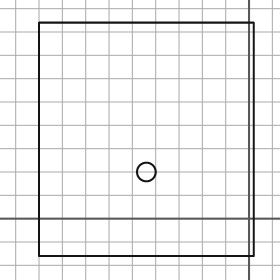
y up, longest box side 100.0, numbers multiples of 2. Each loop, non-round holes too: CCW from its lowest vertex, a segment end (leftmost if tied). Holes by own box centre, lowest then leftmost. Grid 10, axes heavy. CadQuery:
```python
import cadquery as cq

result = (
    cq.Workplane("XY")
    .moveTo(-90.0, -16.0)
    .lineTo(2.0, -16.0)
    .lineTo(2.0, 84.0)
    .lineTo(-90.0, 84.0)
    .close()
    .moveTo(-44.0, 20.0)
    .circle(4.0)
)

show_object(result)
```